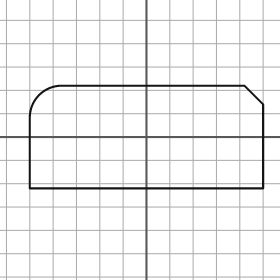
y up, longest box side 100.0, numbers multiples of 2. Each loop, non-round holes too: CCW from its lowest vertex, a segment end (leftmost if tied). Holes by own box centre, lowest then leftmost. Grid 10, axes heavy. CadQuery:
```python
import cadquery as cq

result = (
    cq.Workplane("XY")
    .moveTo(-50.0, -22.0)
    .lineTo(50.0, -22.0)
    .lineTo(50.0, 14.0)
    .lineTo(42.0, 22.0)
    .lineTo(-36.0, 22.0)
    .threePointArc((-46.0, 18.0), (-50.0, 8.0))
    .close()
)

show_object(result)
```